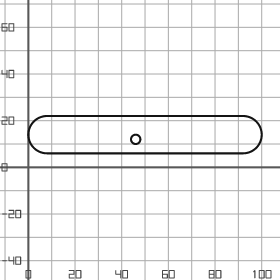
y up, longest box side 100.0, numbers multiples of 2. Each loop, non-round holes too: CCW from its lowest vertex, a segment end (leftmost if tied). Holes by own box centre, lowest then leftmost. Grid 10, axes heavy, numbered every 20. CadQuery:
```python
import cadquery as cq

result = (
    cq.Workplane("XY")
    .moveTo(8.0, 6.0)
    .lineTo(92.0, 6.0)
    .threePointArc((100.0, 14.0), (92.0, 22.0))
    .lineTo(8.0, 22.0)
    .threePointArc((0.0, 14.0), (8.0, 6.0))
    .close()
    .moveTo(46.0, 12.0)
    .circle(2.0)
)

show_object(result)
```